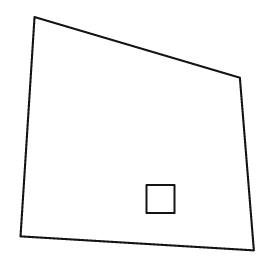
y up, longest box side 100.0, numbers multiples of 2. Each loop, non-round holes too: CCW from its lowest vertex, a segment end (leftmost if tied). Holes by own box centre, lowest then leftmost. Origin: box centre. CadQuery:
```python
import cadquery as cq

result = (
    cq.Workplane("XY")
    .moveTo(50.0, -50.0)
    .lineTo(44.0, 24.0)
    .lineTo(-44.0, 50.0)
    .lineTo(-50.0, -44.0)
    .close()
    .moveTo(4.0, -34.0)
    .lineTo(16.0, -34.0)
    .lineTo(16.0, -22.0)
    .lineTo(4.0, -22.0)
    .close()
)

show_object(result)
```